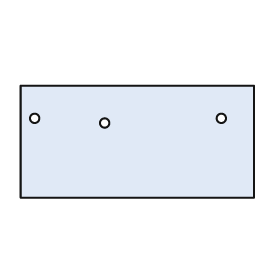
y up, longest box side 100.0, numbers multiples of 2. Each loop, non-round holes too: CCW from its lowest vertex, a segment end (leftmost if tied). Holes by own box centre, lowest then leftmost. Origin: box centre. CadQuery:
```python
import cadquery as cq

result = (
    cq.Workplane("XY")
    .moveTo(-50.0, -24.0)
    .lineTo(50.0, -24.0)
    .lineTo(50.0, 24.0)
    .lineTo(-50.0, 24.0)
    .close()
    .moveTo(-14.0, 8.0)
    .circle(2.0)
    .moveTo(-44.0, 10.0)
    .circle(2.0)
    .moveTo(36.0, 10.0)
    .circle(2.0)
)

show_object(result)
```